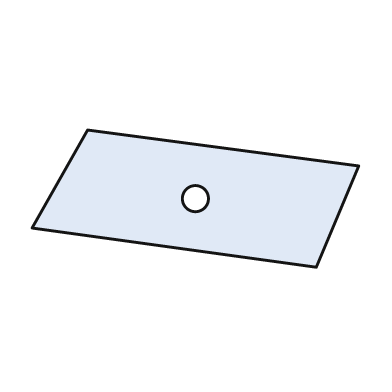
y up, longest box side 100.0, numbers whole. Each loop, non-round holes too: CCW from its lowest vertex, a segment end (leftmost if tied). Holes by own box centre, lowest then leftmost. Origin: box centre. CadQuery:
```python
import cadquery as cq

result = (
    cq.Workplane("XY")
    .moveTo(37.0, -21.0)
    .lineTo(50.0, 10.0)
    .lineTo(-33.0, 21.0)
    .lineTo(-50.0, -9.0)
    .close()
    .moveTo(0.0, 0.0)
    .circle(4.0)
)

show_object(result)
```